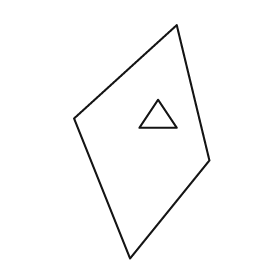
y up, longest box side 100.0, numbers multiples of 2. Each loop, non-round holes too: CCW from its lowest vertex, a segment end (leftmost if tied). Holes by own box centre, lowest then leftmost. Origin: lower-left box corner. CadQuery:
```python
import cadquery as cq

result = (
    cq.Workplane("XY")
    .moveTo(24.0, 0.0)
    .lineTo(58.0, 42.0)
    .lineTo(44.0, 100.0)
    .lineTo(0.0, 60.0)
    .close()
    .moveTo(28.0, 56.0)
    .lineTo(44.0, 56.0)
    .lineTo(36.0, 68.0)
    .close()
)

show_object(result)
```